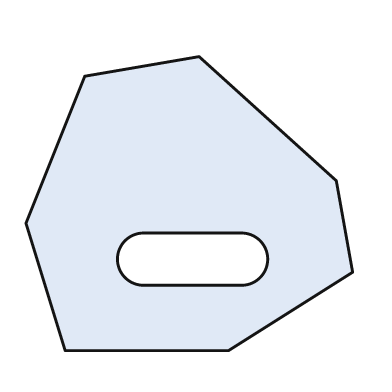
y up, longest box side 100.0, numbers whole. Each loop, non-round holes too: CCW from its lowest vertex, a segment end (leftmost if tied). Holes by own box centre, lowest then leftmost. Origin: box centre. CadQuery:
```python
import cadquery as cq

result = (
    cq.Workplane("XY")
    .moveTo(-38.0, -45.0)
    .lineTo(12.0, -45.0)
    .lineTo(50.0, -21.0)
    .lineTo(45.0, 7.0)
    .lineTo(3.0, 45.0)
    .lineTo(-32.0, 39.0)
    .lineTo(-50.0, -6.0)
    .close()
    .moveTo(-14.0, -25.0)
    .lineTo(16.0, -25.0)
    .threePointArc((24.0, -17.0), (16.0, -9.0))
    .lineTo(-14.0, -9.0)
    .threePointArc((-22.0, -17.0), (-14.0, -25.0))
    .close()
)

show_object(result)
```